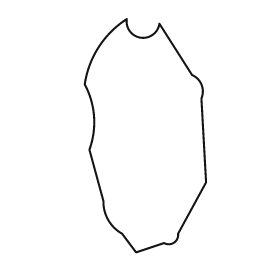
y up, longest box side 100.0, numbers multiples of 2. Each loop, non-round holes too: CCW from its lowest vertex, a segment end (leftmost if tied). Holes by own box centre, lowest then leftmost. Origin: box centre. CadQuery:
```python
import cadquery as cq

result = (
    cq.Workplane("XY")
    .moveTo(-4.0, -50.0)
    .lineTo(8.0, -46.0)
    .threePointArc((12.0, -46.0), (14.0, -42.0))
    .lineTo(26.0, -20.0)
    .lineTo(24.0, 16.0)
    .threePointArc((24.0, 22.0), (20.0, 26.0))
    .lineTo(6.0, 48.0)
    .threePointArc((-2.0, 42.0), (-8.0, 50.0))
    .threePointArc((-20.0, 38.0), (-26.0, 22.0))
    .threePointArc((-22.0, 8.0), (-24.0, -6.0))
    .lineTo(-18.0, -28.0)
    .threePointArc((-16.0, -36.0), (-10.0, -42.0))
    .close()
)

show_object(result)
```